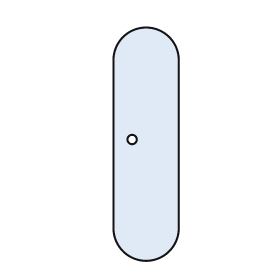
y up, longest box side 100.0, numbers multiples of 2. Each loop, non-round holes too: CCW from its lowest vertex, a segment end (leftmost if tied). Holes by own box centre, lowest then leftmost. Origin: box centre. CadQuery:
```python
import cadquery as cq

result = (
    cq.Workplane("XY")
    .moveTo(-14.0, -36.0)
    .threePointArc((0.0, -50.0), (14.0, -36.0))
    .lineTo(14.0, 36.0)
    .threePointArc((0.0, 50.0), (-14.0, 36.0))
    .close()
    .moveTo(-6.0, 2.0)
    .circle(2.0)
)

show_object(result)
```